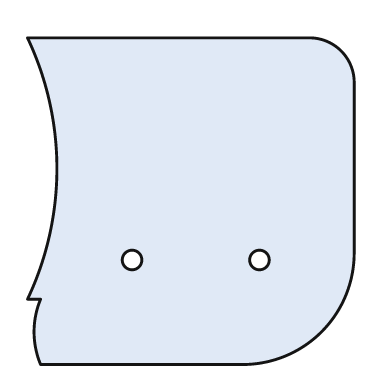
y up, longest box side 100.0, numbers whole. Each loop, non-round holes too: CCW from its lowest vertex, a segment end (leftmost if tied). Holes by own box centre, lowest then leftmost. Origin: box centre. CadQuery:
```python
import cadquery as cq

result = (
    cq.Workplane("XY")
    .moveTo(-46.0, -50.0)
    .lineTo(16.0, -50.0)
    .threePointArc((40.0, -40.0), (50.0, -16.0))
    .lineTo(50.0, 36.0)
    .threePointArc((46.0, 46.0), (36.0, 50.0))
    .lineTo(-50.0, 50.0)
    .threePointArc((-41.0, 10.0), (-50.0, -30.0))
    .lineTo(-46.0, -30.0)
    .threePointArc((-48.0, -40.0), (-46.0, -50.0))
    .close()
    .moveTo(-18.0, -18.0)
    .circle(3.0)
    .moveTo(21.0, -18.0)
    .circle(3.0)
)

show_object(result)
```